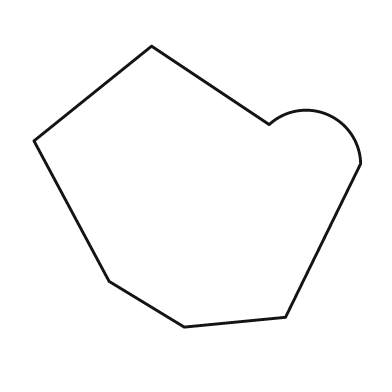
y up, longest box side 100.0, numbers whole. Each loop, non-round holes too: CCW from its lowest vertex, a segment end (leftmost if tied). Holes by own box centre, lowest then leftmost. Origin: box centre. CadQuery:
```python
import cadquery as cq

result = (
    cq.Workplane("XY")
    .moveTo(-4.0, -43.0)
    .lineTo(27.0, -40.0)
    .lineTo(50.0, 7.0)
    .threePointArc((40.0, 22.0), (22.0, 19.0))
    .lineTo(-14.0, 43.0)
    .lineTo(-50.0, 14.0)
    .lineTo(-27.0, -29.0)
    .close()
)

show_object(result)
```